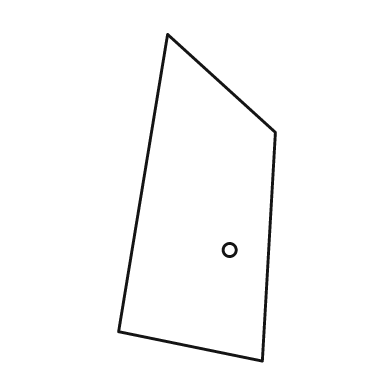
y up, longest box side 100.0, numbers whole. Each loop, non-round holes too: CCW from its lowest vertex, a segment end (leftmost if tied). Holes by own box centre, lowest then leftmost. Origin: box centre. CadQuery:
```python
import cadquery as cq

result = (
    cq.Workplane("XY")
    .moveTo(20.0, -50.0)
    .lineTo(24.0, 20.0)
    .lineTo(-9.0, 50.0)
    .lineTo(-24.0, -41.0)
    .close()
    .moveTo(10.0, -16.0)
    .circle(2.0)
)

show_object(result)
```